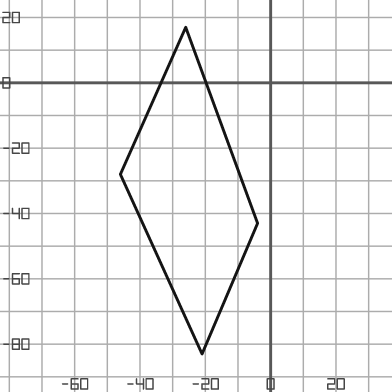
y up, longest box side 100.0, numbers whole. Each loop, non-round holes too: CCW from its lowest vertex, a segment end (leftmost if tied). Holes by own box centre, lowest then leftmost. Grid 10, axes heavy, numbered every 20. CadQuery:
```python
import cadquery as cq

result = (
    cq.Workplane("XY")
    .moveTo(-21.0, -83.0)
    .lineTo(-4.0, -43.0)
    .lineTo(-26.0, 17.0)
    .lineTo(-46.0, -28.0)
    .close()
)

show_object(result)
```